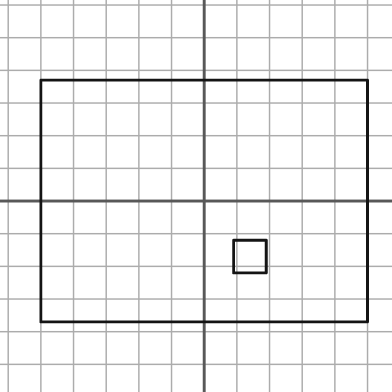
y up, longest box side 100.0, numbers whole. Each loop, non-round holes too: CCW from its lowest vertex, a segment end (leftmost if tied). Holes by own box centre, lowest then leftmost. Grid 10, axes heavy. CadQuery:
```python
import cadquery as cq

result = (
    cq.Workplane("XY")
    .moveTo(-50.0, -37.0)
    .lineTo(50.0, -37.0)
    .lineTo(50.0, 37.0)
    .lineTo(-50.0, 37.0)
    .close()
    .moveTo(9.0, -22.0)
    .lineTo(19.0, -22.0)
    .lineTo(19.0, -12.0)
    .lineTo(9.0, -12.0)
    .close()
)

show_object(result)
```